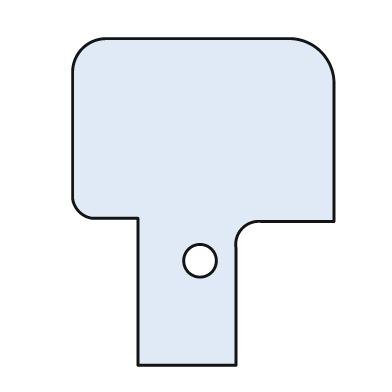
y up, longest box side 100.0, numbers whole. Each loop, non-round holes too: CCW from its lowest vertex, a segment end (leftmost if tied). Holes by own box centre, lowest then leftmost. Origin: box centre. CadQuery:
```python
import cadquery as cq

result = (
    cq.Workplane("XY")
    .moveTo(-20.0, -50.0)
    .lineTo(10.0, -50.0)
    .lineTo(10.0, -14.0)
    .threePointArc((12.0, -8.0), (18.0, -6.0))
    .lineTo(40.0, -6.0)
    .lineTo(40.0, 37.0)
    .threePointArc((36.0, 46.0), (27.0, 50.0))
    .lineTo(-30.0, 50.0)
    .threePointArc((-37.0, 47.0), (-40.0, 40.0))
    .lineTo(-40.0, 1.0)
    .threePointArc((-38.0, -3.0), (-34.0, -5.0))
    .lineTo(-20.0, -5.0)
    .close()
    .moveTo(-1.0, -18.0)
    .circle(5.0)
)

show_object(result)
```